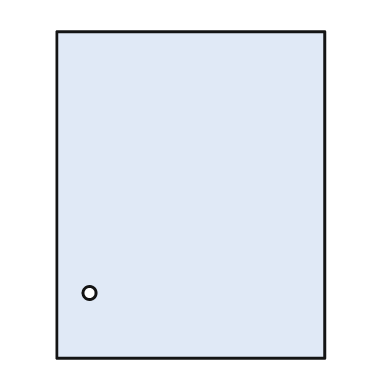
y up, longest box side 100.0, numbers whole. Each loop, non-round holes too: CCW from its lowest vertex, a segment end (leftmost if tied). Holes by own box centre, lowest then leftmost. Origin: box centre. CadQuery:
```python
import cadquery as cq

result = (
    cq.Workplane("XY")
    .moveTo(-41.0, -50.0)
    .lineTo(41.0, -50.0)
    .lineTo(41.0, 50.0)
    .lineTo(-41.0, 50.0)
    .close()
    .moveTo(-31.0, -30.0)
    .circle(2.0)
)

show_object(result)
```